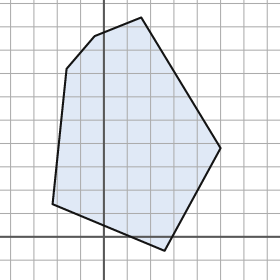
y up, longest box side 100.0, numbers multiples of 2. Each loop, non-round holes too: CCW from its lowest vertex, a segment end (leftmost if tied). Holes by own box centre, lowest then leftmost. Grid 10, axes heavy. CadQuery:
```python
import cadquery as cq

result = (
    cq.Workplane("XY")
    .moveTo(26.0, -6.0)
    .lineTo(50.0, 38.0)
    .lineTo(16.0, 94.0)
    .lineTo(-4.0, 86.0)
    .lineTo(-16.0, 72.0)
    .lineTo(-22.0, 14.0)
    .close()
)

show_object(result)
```